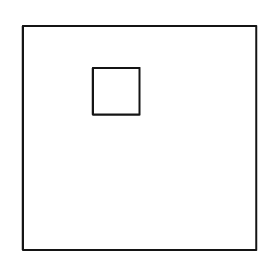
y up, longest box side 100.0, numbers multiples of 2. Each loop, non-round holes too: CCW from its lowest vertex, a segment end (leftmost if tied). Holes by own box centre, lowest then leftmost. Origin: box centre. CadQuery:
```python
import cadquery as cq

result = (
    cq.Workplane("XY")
    .moveTo(-50.0, -48.0)
    .lineTo(50.0, -48.0)
    .lineTo(50.0, 48.0)
    .lineTo(-50.0, 48.0)
    .close()
    .moveTo(-20.0, 10.0)
    .lineTo(0.0, 10.0)
    .lineTo(0.0, 30.0)
    .lineTo(-20.0, 30.0)
    .close()
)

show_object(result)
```